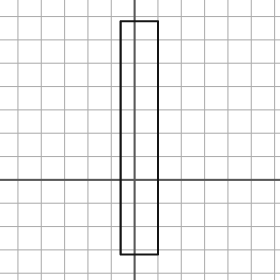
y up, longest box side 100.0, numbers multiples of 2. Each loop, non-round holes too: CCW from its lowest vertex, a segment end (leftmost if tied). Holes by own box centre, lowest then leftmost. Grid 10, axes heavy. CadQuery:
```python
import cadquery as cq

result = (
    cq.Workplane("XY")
    .moveTo(-6.0, -32.0)
    .lineTo(10.0, -32.0)
    .lineTo(10.0, 68.0)
    .lineTo(-6.0, 68.0)
    .close()
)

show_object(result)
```